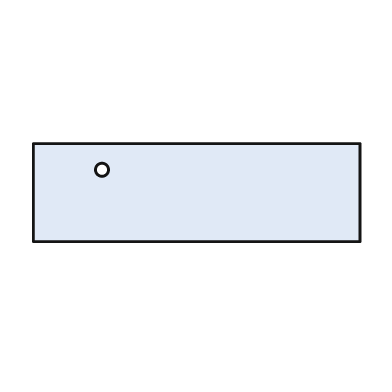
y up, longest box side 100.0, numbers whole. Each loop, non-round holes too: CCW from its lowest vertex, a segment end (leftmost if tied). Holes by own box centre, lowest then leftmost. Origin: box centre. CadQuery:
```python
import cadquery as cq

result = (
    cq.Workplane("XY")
    .moveTo(-50.0, -15.0)
    .lineTo(50.0, -15.0)
    .lineTo(50.0, 15.0)
    .lineTo(-50.0, 15.0)
    .close()
    .moveTo(-29.0, 7.0)
    .circle(2.0)
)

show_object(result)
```